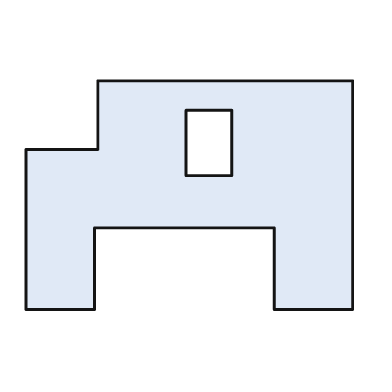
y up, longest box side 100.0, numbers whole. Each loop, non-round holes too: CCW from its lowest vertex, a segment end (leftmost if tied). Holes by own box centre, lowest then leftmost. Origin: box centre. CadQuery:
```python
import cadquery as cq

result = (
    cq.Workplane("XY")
    .moveTo(-50.0, -35.0)
    .lineTo(-29.0, -35.0)
    .lineTo(-29.0, -10.0)
    .lineTo(26.0, -10.0)
    .lineTo(26.0, -35.0)
    .lineTo(50.0, -35.0)
    .lineTo(50.0, 35.0)
    .lineTo(-28.0, 35.0)
    .lineTo(-28.0, 14.0)
    .lineTo(-50.0, 14.0)
    .close()
    .moveTo(-1.0, 6.0)
    .lineTo(13.0, 6.0)
    .lineTo(13.0, 26.0)
    .lineTo(-1.0, 26.0)
    .close()
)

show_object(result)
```